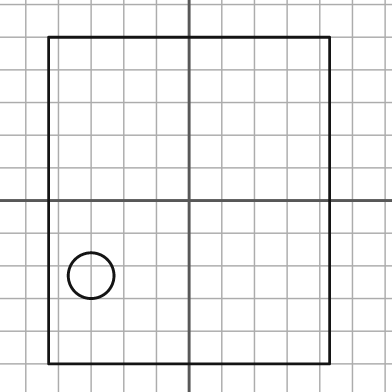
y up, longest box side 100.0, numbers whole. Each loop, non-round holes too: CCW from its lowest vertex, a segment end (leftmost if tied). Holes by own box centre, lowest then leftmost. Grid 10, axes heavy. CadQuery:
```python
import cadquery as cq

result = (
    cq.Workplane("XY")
    .moveTo(-43.0, -50.0)
    .lineTo(43.0, -50.0)
    .lineTo(43.0, 50.0)
    .lineTo(-43.0, 50.0)
    .close()
    .moveTo(-30.0, -23.0)
    .circle(7.0)
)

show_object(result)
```